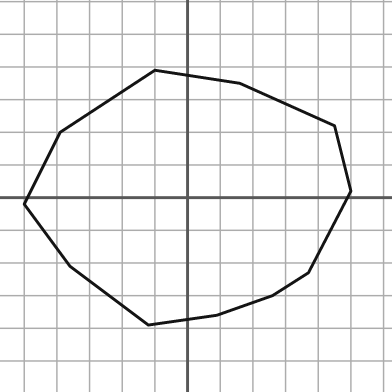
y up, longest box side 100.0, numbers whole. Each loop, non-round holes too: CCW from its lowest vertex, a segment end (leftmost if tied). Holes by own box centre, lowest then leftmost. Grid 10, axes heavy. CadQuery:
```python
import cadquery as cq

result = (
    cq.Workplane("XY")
    .moveTo(-12.0, -39.0)
    .lineTo(9.0, -36.0)
    .lineTo(26.0, -30.0)
    .lineTo(37.0, -23.0)
    .lineTo(50.0, 2.0)
    .lineTo(45.0, 22.0)
    .lineTo(16.0, 35.0)
    .lineTo(-10.0, 39.0)
    .lineTo(-39.0, 20.0)
    .lineTo(-50.0, -2.0)
    .lineTo(-36.0, -21.0)
    .close()
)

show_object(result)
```